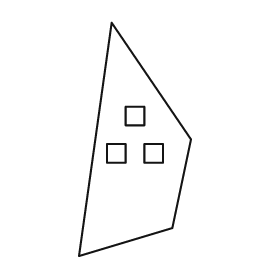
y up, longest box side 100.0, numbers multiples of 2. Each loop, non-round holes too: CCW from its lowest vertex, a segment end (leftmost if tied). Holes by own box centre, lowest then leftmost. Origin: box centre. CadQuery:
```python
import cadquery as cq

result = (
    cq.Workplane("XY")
    .moveTo(-24.0, -50.0)
    .lineTo(16.0, -38.0)
    .lineTo(24.0, 0.0)
    .lineTo(-10.0, 50.0)
    .close()
    .moveTo(-12.0, -10.0)
    .lineTo(-4.0, -10.0)
    .lineTo(-4.0, -2.0)
    .lineTo(-12.0, -2.0)
    .close()
    .moveTo(4.0, -10.0)
    .lineTo(12.0, -10.0)
    .lineTo(12.0, -2.0)
    .lineTo(4.0, -2.0)
    .close()
    .moveTo(-4.0, 6.0)
    .lineTo(4.0, 6.0)
    .lineTo(4.0, 14.0)
    .lineTo(-4.0, 14.0)
    .close()
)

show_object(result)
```